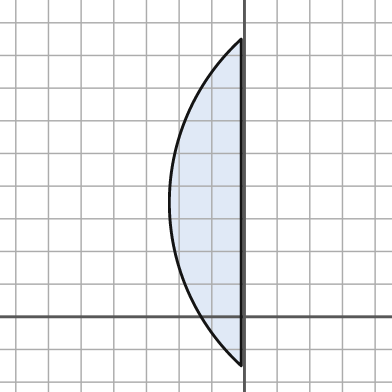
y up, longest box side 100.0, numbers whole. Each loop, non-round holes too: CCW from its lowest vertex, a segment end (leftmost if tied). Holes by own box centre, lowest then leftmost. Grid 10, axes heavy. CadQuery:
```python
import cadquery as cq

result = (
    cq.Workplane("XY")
    .moveTo(-1.0, -15.0)
    .lineTo(-1.0, 85.0)
    .threePointArc((-23.0, 35.0), (-1.0, -15.0))
    .close()
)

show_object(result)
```